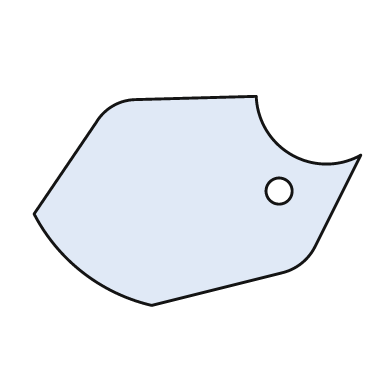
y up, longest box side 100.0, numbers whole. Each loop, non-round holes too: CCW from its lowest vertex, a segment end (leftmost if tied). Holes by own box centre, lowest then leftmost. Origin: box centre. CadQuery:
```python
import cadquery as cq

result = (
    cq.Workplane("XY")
    .moveTo(-14.0, -32.0)
    .lineTo(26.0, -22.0)
    .threePointArc((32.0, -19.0), (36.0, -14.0))
    .lineTo(50.0, 14.0)
    .threePointArc((29.0, 14.0), (18.0, 32.0))
    .lineTo(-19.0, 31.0)
    .threePointArc((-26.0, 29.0), (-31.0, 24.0))
    .lineTo(-50.0, -4.0)
    .threePointArc((-35.0, -22.0), (-14.0, -32.0))
    .close()
    .moveTo(25.0, 3.0)
    .circle(4.0)
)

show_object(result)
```